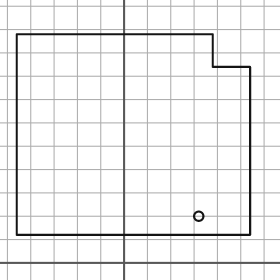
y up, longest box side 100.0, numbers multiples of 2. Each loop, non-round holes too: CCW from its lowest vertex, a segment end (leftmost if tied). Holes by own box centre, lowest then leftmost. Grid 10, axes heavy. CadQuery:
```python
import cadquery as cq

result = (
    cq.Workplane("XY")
    .moveTo(-46.0, 12.0)
    .lineTo(54.0, 12.0)
    .lineTo(54.0, 84.0)
    .lineTo(38.0, 84.0)
    .lineTo(38.0, 98.0)
    .lineTo(-46.0, 98.0)
    .close()
    .moveTo(32.0, 20.0)
    .circle(2.0)
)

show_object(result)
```